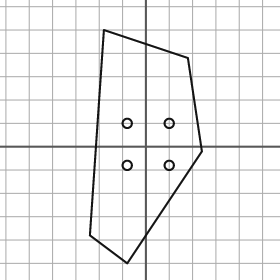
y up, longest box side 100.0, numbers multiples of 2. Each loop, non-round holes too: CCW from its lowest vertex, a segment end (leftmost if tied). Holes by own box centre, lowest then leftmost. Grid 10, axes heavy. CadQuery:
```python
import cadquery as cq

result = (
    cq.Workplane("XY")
    .moveTo(-8.0, -50.0)
    .lineTo(24.0, -2.0)
    .lineTo(18.0, 38.0)
    .lineTo(-18.0, 50.0)
    .lineTo(-24.0, -38.0)
    .close()
    .moveTo(-8.0, -8.0)
    .circle(2.0)
    .moveTo(10.0, -8.0)
    .circle(2.0)
    .moveTo(-8.0, 10.0)
    .circle(2.0)
    .moveTo(10.0, 10.0)
    .circle(2.0)
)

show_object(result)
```